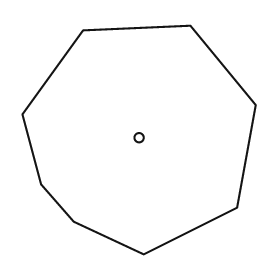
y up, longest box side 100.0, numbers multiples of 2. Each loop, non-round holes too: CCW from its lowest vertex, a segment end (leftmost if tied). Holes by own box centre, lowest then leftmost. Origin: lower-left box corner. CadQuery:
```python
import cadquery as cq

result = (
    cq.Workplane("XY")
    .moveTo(52.0, 0.0)
    .lineTo(92.0, 20.0)
    .lineTo(100.0, 64.0)
    .lineTo(72.0, 98.0)
    .lineTo(26.0, 96.0)
    .lineTo(0.0, 60.0)
    .lineTo(8.0, 30.0)
    .lineTo(22.0, 14.0)
    .close()
    .moveTo(50.0, 50.0)
    .circle(2.0)
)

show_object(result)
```